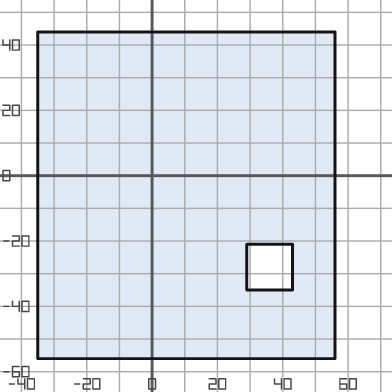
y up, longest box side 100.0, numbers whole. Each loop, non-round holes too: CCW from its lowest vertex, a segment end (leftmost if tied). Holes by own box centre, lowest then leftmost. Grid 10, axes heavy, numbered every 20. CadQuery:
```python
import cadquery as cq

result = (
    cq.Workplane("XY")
    .moveTo(-35.0, -56.0)
    .lineTo(56.0, -56.0)
    .lineTo(56.0, 44.0)
    .lineTo(-35.0, 44.0)
    .close()
    .moveTo(29.0, -35.0)
    .lineTo(43.0, -35.0)
    .lineTo(43.0, -21.0)
    .lineTo(29.0, -21.0)
    .close()
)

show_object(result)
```